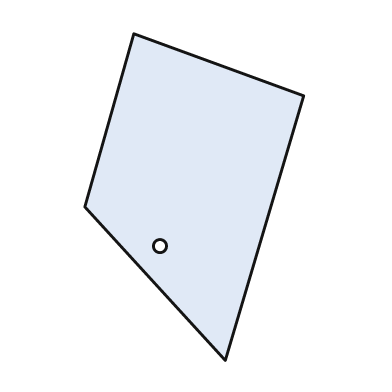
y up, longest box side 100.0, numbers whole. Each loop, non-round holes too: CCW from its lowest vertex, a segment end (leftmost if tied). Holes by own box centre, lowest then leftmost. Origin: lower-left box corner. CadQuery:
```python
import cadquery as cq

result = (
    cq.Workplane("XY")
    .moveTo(43.0, 0.0)
    .lineTo(67.0, 81.0)
    .lineTo(15.0, 100.0)
    .lineTo(0.0, 47.0)
    .close()
    .moveTo(23.0, 35.0)
    .circle(2.0)
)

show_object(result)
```